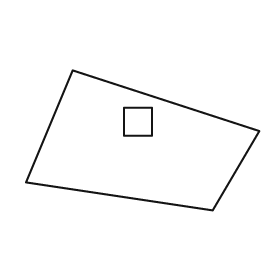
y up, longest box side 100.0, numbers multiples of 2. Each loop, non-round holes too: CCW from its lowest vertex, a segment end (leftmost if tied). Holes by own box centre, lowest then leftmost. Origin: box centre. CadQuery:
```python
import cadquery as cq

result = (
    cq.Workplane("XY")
    .moveTo(30.0, -30.0)
    .lineTo(50.0, 4.0)
    .lineTo(-30.0, 30.0)
    .lineTo(-50.0, -18.0)
    .close()
    .moveTo(-8.0, 2.0)
    .lineTo(4.0, 2.0)
    .lineTo(4.0, 14.0)
    .lineTo(-8.0, 14.0)
    .close()
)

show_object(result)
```